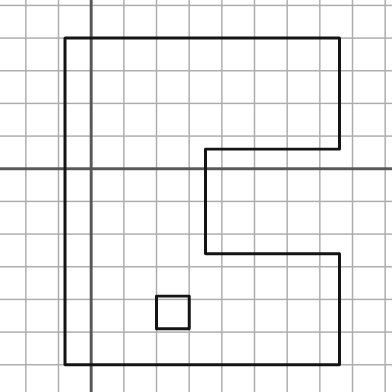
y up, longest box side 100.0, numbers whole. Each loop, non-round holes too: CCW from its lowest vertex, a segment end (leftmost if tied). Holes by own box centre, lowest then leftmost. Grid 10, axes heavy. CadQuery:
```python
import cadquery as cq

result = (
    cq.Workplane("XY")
    .moveTo(-8.0, -60.0)
    .lineTo(76.0, -60.0)
    .lineTo(76.0, -26.0)
    .lineTo(35.0, -26.0)
    .lineTo(35.0, 6.0)
    .lineTo(76.0, 6.0)
    .lineTo(76.0, 40.0)
    .lineTo(-8.0, 40.0)
    .close()
    .moveTo(20.0, -49.0)
    .lineTo(30.0, -49.0)
    .lineTo(30.0, -39.0)
    .lineTo(20.0, -39.0)
    .close()
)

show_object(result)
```